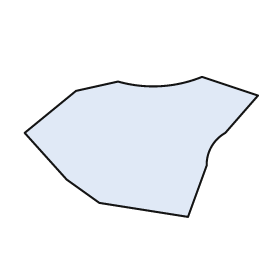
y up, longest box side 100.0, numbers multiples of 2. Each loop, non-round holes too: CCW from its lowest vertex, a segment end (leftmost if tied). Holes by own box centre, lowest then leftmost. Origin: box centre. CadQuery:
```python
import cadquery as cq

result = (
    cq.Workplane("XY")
    .moveTo(20.0, -30.0)
    .lineTo(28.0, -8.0)
    .threePointArc((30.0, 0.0), (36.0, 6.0))
    .lineTo(50.0, 22.0)
    .lineTo(26.0, 30.0)
    .threePointArc((8.0, 26.0), (-10.0, 28.0))
    .lineTo(-28.0, 24.0)
    .lineTo(-50.0, 6.0)
    .lineTo(-32.0, -14.0)
    .lineTo(-18.0, -24.0)
    .close()
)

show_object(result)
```